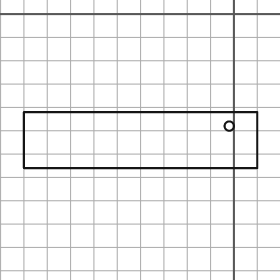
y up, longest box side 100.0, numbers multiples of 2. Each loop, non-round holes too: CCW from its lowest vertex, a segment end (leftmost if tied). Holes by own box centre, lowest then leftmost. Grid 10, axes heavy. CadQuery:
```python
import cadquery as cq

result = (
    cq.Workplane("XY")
    .moveTo(-90.0, -66.0)
    .lineTo(10.0, -66.0)
    .lineTo(10.0, -42.0)
    .lineTo(-90.0, -42.0)
    .close()
    .moveTo(-2.0, -48.0)
    .circle(2.0)
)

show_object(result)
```